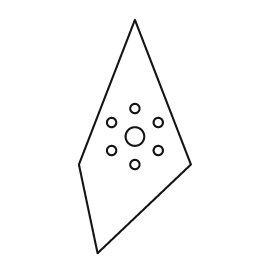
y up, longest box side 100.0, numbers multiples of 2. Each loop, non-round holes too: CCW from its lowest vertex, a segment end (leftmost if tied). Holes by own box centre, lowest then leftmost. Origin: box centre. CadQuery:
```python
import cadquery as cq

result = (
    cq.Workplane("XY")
    .moveTo(-16.0, -50.0)
    .lineTo(24.0, -12.0)
    .lineTo(0.0, 50.0)
    .lineTo(-24.0, -12.0)
    .close()
    .moveTo(0.0, -12.0)
    .circle(2.0)
    .moveTo(-10.0, -6.0)
    .circle(2.0)
    .moveTo(10.0, -6.0)
    .circle(2.0)
    .moveTo(0.0, 0.0)
    .circle(4.0)
    .moveTo(-10.0, 6.0)
    .circle(2.0)
    .moveTo(10.0, 6.0)
    .circle(2.0)
    .moveTo(0.0, 12.0)
    .circle(2.0)
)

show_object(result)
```